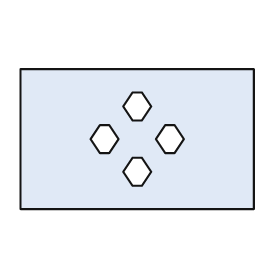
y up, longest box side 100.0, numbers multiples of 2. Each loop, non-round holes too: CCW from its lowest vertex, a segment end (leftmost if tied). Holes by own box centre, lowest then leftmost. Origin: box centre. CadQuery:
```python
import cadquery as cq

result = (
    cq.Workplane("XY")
    .moveTo(-50.0, -30.0)
    .lineTo(50.0, -30.0)
    .lineTo(50.0, 30.0)
    .lineTo(-50.0, 30.0)
    .close()
    .moveTo(-2.0, -20.0)
    .lineTo(2.0, -20.0)
    .lineTo(6.0, -14.0)
    .lineTo(2.0, -8.0)
    .lineTo(-2.0, -8.0)
    .lineTo(-6.0, -14.0)
    .close()
    .moveTo(-16.0, -6.0)
    .lineTo(-12.0, -6.0)
    .lineTo(-8.0, 0.0)
    .lineTo(-12.0, 6.0)
    .lineTo(-16.0, 6.0)
    .lineTo(-20.0, 0.0)
    .close()
    .moveTo(12.0, -6.0)
    .lineTo(16.0, -6.0)
    .lineTo(20.0, 0.0)
    .lineTo(16.0, 6.0)
    .lineTo(12.0, 6.0)
    .lineTo(8.0, 0.0)
    .close()
    .moveTo(-2.0, 8.0)
    .lineTo(2.0, 8.0)
    .lineTo(6.0, 14.0)
    .lineTo(2.0, 20.0)
    .lineTo(-2.0, 20.0)
    .lineTo(-6.0, 14.0)
    .close()
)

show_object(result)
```